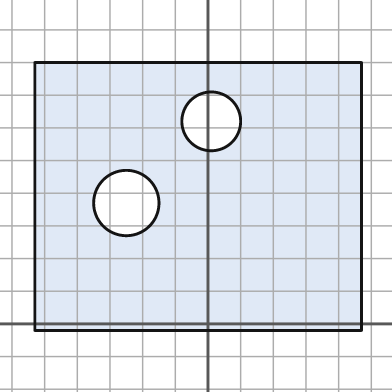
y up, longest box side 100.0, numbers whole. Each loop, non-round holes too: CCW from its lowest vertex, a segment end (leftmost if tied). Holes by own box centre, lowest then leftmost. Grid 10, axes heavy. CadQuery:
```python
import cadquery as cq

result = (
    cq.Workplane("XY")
    .moveTo(-53.0, -2.0)
    .lineTo(47.0, -2.0)
    .lineTo(47.0, 80.0)
    .lineTo(-53.0, 80.0)
    .close()
    .moveTo(-25.0, 37.0)
    .circle(10.0)
    .moveTo(1.0, 62.0)
    .circle(9.0)
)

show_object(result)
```